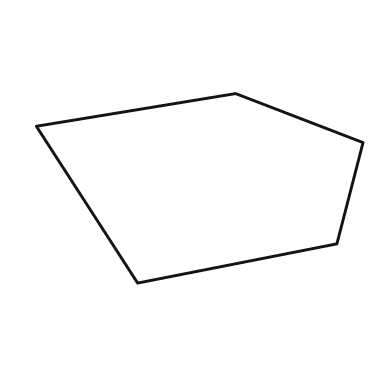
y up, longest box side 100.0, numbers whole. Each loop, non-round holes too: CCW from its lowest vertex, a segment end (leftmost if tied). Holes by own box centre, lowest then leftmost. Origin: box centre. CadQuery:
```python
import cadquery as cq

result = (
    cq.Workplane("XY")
    .moveTo(-19.0, -29.0)
    .lineTo(42.0, -17.0)
    .lineTo(50.0, 14.0)
    .lineTo(11.0, 29.0)
    .lineTo(-50.0, 19.0)
    .close()
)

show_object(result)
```